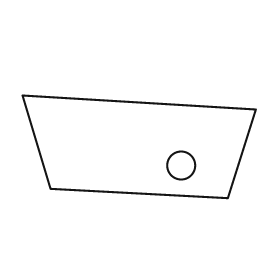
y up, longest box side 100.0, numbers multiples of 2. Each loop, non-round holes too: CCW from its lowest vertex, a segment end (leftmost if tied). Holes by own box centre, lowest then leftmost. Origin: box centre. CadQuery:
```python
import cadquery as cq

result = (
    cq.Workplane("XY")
    .moveTo(38.0, -22.0)
    .lineTo(50.0, 16.0)
    .lineTo(-50.0, 22.0)
    .lineTo(-38.0, -18.0)
    .close()
    .moveTo(18.0, -8.0)
    .circle(6.0)
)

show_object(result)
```